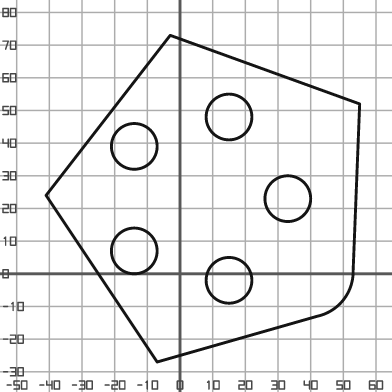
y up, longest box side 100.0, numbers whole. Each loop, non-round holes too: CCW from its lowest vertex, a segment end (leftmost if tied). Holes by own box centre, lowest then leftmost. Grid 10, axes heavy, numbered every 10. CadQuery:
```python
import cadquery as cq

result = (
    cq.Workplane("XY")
    .moveTo(-7.0, -27.0)
    .lineTo(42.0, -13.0)
    .threePointArc((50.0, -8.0), (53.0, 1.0))
    .lineTo(55.0, 52.0)
    .lineTo(-3.0, 73.0)
    .lineTo(-41.0, 24.0)
    .close()
    .moveTo(15.0, -2.0)
    .circle(7.0)
    .moveTo(-14.0, 7.0)
    .circle(7.0)
    .moveTo(33.0, 23.0)
    .circle(7.0)
    .moveTo(-14.0, 39.0)
    .circle(7.0)
    .moveTo(15.0, 48.0)
    .circle(7.0)
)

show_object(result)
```